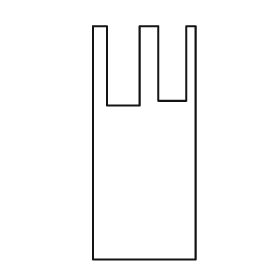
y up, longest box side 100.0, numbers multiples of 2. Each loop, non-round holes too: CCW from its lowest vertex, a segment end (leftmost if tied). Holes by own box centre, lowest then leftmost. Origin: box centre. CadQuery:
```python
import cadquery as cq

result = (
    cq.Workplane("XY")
    .moveTo(-22.0, -50.0)
    .lineTo(22.0, -50.0)
    .lineTo(22.0, 50.0)
    .lineTo(18.0, 50.0)
    .lineTo(18.0, 18.0)
    .lineTo(6.0, 18.0)
    .lineTo(6.0, 50.0)
    .lineTo(-2.0, 50.0)
    .lineTo(-2.0, 16.0)
    .lineTo(-16.0, 16.0)
    .lineTo(-16.0, 50.0)
    .lineTo(-22.0, 50.0)
    .close()
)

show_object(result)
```